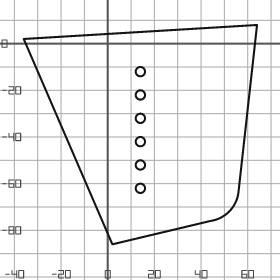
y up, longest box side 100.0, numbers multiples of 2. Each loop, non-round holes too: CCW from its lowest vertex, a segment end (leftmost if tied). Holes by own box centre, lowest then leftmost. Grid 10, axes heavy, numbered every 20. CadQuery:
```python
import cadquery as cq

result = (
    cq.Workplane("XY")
    .moveTo(2.0, -86.0)
    .lineTo(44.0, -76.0)
    .threePointArc((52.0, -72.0), (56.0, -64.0))
    .lineTo(64.0, 8.0)
    .lineTo(-36.0, 2.0)
    .close()
    .moveTo(14.0, -62.0)
    .circle(2.0)
    .moveTo(14.0, -52.0)
    .circle(2.0)
    .moveTo(14.0, -42.0)
    .circle(2.0)
    .moveTo(14.0, -32.0)
    .circle(2.0)
    .moveTo(14.0, -22.0)
    .circle(2.0)
    .moveTo(14.0, -12.0)
    .circle(2.0)
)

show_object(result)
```